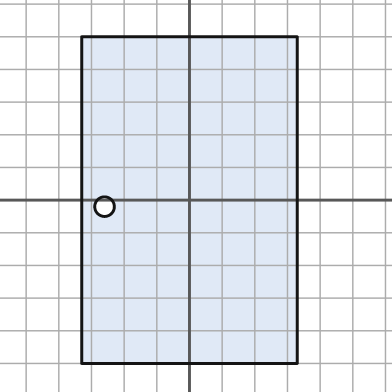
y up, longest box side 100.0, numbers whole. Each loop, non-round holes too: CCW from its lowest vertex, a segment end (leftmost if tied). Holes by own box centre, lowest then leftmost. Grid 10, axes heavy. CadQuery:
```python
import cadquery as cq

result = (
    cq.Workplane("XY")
    .moveTo(-33.0, -50.0)
    .lineTo(33.0, -50.0)
    .lineTo(33.0, 50.0)
    .lineTo(-33.0, 50.0)
    .close()
    .moveTo(-26.0, -2.0)
    .circle(3.0)
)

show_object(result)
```